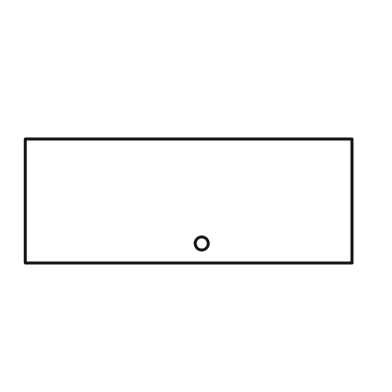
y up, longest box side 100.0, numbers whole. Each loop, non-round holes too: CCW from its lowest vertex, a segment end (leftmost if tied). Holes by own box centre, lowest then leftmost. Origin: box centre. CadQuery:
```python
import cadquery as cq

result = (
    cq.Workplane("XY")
    .moveTo(-50.0, -19.0)
    .lineTo(50.0, -19.0)
    .lineTo(50.0, 19.0)
    .lineTo(-50.0, 19.0)
    .close()
    .moveTo(4.0, -13.0)
    .circle(2.0)
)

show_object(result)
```